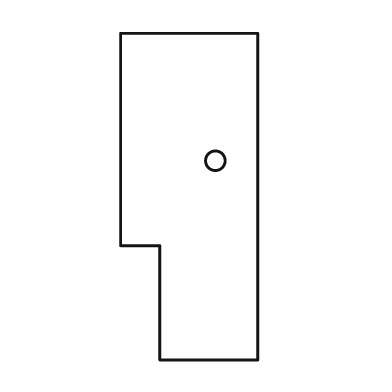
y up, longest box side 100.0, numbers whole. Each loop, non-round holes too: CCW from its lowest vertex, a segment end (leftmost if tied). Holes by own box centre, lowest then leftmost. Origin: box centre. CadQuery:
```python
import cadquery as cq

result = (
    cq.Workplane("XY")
    .moveTo(-9.0, -50.0)
    .lineTo(21.0, -50.0)
    .lineTo(21.0, 50.0)
    .lineTo(-21.0, 50.0)
    .lineTo(-21.0, -15.0)
    .lineTo(-9.0, -15.0)
    .close()
    .moveTo(8.0, 11.0)
    .circle(3.0)
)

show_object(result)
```